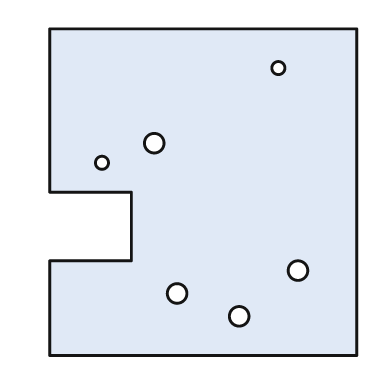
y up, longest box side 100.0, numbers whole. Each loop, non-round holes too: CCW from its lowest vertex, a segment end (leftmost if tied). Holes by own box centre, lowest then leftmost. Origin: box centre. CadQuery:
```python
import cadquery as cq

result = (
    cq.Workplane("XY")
    .moveTo(-47.0, -50.0)
    .lineTo(47.0, -50.0)
    .lineTo(47.0, 50.0)
    .lineTo(-47.0, 50.0)
    .lineTo(-47.0, 0.0)
    .lineTo(-22.0, 0.0)
    .lineTo(-22.0, -21.0)
    .lineTo(-47.0, -21.0)
    .close()
    .moveTo(11.0, -38.0)
    .circle(3.0)
    .moveTo(-8.0, -31.0)
    .circle(3.0)
    .moveTo(29.0, -24.0)
    .circle(3.0)
    .moveTo(-31.0, 9.0)
    .circle(2.0)
    .moveTo(-15.0, 15.0)
    .circle(3.0)
    .moveTo(23.0, 38.0)
    .circle(2.0)
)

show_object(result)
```